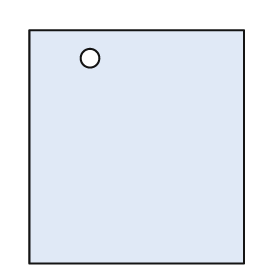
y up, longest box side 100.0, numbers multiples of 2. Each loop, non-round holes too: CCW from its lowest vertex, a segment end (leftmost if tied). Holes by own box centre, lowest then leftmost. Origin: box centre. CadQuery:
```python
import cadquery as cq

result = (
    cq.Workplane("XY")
    .moveTo(-46.0, -50.0)
    .lineTo(46.0, -50.0)
    .lineTo(46.0, 50.0)
    .lineTo(-46.0, 50.0)
    .close()
    .moveTo(-20.0, 38.0)
    .circle(4.0)
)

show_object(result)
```